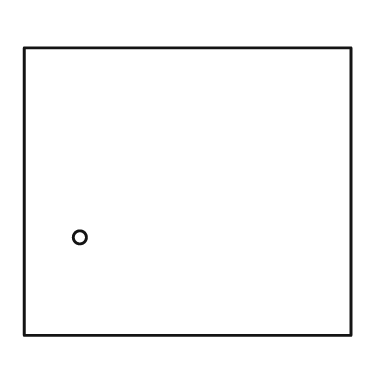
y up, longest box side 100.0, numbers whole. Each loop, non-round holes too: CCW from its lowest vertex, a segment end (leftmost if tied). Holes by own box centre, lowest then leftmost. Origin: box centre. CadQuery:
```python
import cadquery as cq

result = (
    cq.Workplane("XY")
    .moveTo(-50.0, -44.0)
    .lineTo(50.0, -44.0)
    .lineTo(50.0, 44.0)
    .lineTo(-50.0, 44.0)
    .close()
    .moveTo(-33.0, -14.0)
    .circle(2.0)
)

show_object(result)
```